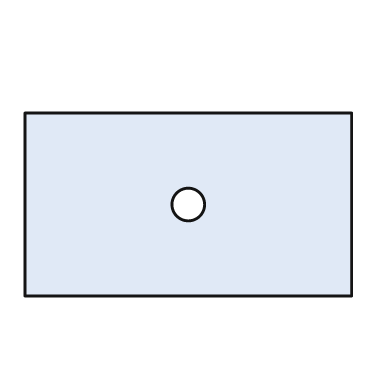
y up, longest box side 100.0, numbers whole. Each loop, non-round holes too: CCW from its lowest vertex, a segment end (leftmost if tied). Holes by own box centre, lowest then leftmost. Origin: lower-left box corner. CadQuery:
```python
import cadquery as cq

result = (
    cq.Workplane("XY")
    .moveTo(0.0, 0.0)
    .lineTo(100.0, 0.0)
    .lineTo(100.0, 56.0)
    .lineTo(0.0, 56.0)
    .close()
    .moveTo(50.0, 28.0)
    .circle(5.0)
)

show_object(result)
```